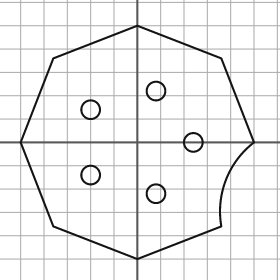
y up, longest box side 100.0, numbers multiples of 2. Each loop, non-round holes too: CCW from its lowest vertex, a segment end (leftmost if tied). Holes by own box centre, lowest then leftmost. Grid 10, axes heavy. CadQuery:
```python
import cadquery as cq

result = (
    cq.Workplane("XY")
    .moveTo(0.0, -50.0)
    .lineTo(36.0, -36.0)
    .threePointArc((38.0, -16.0), (50.0, 0.0))
    .lineTo(36.0, 36.0)
    .lineTo(0.0, 50.0)
    .lineTo(-36.0, 36.0)
    .lineTo(-50.0, 0.0)
    .lineTo(-36.0, -36.0)
    .close()
    .moveTo(8.0, -22.0)
    .circle(4.0)
    .moveTo(-20.0, -14.0)
    .circle(4.0)
    .moveTo(24.0, 0.0)
    .circle(4.0)
    .moveTo(-20.0, 14.0)
    .circle(4.0)
    .moveTo(8.0, 22.0)
    .circle(4.0)
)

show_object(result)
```